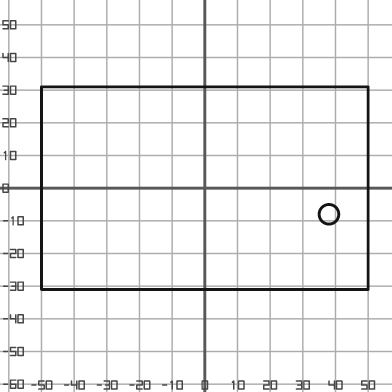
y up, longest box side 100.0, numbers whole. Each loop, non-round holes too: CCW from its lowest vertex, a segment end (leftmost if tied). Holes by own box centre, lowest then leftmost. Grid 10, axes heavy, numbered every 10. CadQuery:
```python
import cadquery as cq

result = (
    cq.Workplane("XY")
    .moveTo(-50.0, -31.0)
    .lineTo(50.0, -31.0)
    .lineTo(50.0, 31.0)
    .lineTo(-50.0, 31.0)
    .close()
    .moveTo(38.0, -8.0)
    .circle(3.0)
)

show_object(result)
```